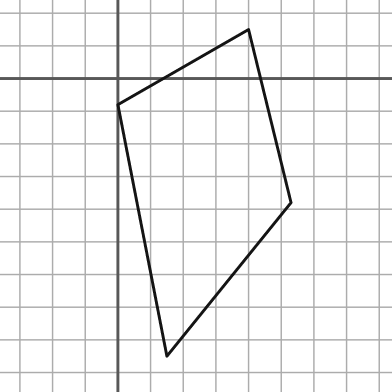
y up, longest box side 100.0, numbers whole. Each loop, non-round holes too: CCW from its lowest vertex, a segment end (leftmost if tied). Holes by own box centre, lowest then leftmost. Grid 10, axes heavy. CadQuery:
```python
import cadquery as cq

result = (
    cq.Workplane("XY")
    .moveTo(15.0, -85.0)
    .lineTo(53.0, -38.0)
    .lineTo(40.0, 15.0)
    .lineTo(0.0, -8.0)
    .close()
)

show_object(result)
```